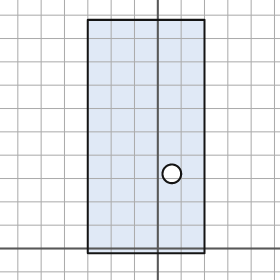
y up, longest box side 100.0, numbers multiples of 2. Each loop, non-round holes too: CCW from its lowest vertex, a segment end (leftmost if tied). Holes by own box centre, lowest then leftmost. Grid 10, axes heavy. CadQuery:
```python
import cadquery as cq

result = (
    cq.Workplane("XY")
    .moveTo(-30.0, -2.0)
    .lineTo(20.0, -2.0)
    .lineTo(20.0, 98.0)
    .lineTo(-30.0, 98.0)
    .close()
    .moveTo(6.0, 32.0)
    .circle(4.0)
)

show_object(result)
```